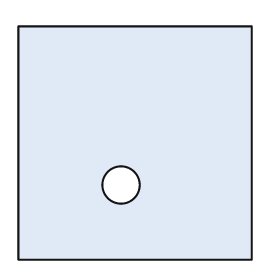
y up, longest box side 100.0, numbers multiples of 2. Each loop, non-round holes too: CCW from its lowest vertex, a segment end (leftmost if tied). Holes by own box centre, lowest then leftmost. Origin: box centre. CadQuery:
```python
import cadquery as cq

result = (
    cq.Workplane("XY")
    .moveTo(-50.0, -50.0)
    .lineTo(50.0, -50.0)
    .lineTo(50.0, 50.0)
    .lineTo(-50.0, 50.0)
    .close()
    .moveTo(-6.0, -18.0)
    .circle(8.0)
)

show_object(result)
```